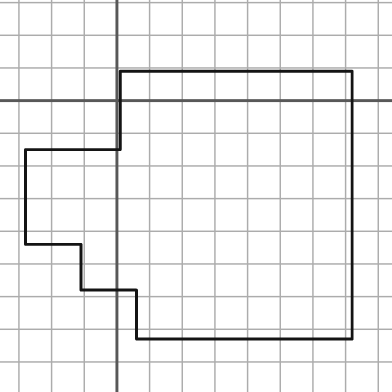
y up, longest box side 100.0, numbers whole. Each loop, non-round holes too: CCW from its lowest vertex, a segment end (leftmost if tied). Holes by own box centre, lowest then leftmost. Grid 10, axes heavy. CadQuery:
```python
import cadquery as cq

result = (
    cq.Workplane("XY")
    .moveTo(6.0, -73.0)
    .lineTo(72.0, -73.0)
    .lineTo(72.0, 9.0)
    .lineTo(1.0, 9.0)
    .lineTo(1.0, -15.0)
    .lineTo(-28.0, -15.0)
    .lineTo(-28.0, -44.0)
    .lineTo(-11.0, -44.0)
    .lineTo(-11.0, -58.0)
    .lineTo(6.0, -58.0)
    .close()
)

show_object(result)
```